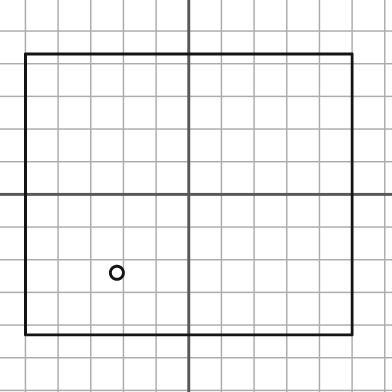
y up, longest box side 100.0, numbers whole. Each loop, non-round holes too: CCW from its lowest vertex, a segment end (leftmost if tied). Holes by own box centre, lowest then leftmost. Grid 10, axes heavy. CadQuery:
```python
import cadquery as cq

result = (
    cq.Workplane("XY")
    .moveTo(-50.0, -43.0)
    .lineTo(50.0, -43.0)
    .lineTo(50.0, 43.0)
    .lineTo(-50.0, 43.0)
    .close()
    .moveTo(-22.0, -24.0)
    .circle(2.0)
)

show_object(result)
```